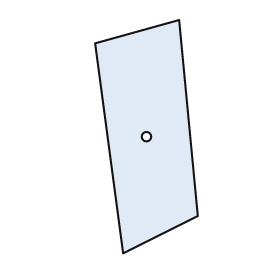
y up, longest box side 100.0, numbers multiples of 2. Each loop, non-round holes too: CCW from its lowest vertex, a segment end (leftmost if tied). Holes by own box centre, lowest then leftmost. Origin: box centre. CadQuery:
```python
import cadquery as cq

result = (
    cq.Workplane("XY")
    .moveTo(-10.0, -50.0)
    .lineTo(22.0, -34.0)
    .lineTo(14.0, 50.0)
    .lineTo(-22.0, 40.0)
    .close()
    .moveTo(0.0, 0.0)
    .circle(2.0)
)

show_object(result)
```